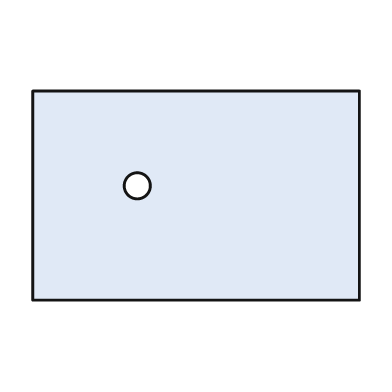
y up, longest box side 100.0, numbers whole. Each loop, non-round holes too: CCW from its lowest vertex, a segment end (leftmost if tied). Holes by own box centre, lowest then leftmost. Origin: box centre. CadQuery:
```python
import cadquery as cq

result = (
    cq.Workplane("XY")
    .moveTo(-50.0, -32.0)
    .lineTo(50.0, -32.0)
    .lineTo(50.0, 32.0)
    .lineTo(-50.0, 32.0)
    .close()
    .moveTo(-18.0, 3.0)
    .circle(4.0)
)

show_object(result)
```